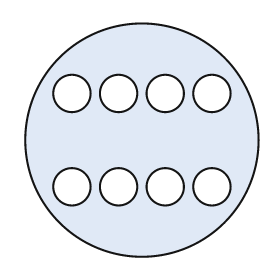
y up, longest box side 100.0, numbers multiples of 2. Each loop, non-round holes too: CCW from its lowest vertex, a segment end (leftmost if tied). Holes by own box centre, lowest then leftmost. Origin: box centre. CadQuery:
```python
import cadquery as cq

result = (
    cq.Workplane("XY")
    .moveTo(0.0, 0.0)
    .circle(50.0)
    .moveTo(-30.0, -20.0)
    .circle(8.0)
    .moveTo(-10.0, -20.0)
    .circle(8.0)
    .moveTo(10.0, -20.0)
    .circle(8.0)
    .moveTo(30.0, -20.0)
    .circle(8.0)
    .moveTo(-30.0, 20.0)
    .circle(8.0)
    .moveTo(-10.0, 20.0)
    .circle(8.0)
    .moveTo(10.0, 20.0)
    .circle(8.0)
    .moveTo(30.0, 20.0)
    .circle(8.0)
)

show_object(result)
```